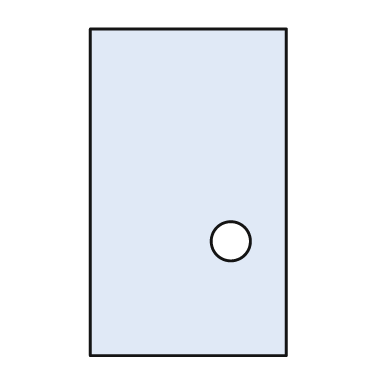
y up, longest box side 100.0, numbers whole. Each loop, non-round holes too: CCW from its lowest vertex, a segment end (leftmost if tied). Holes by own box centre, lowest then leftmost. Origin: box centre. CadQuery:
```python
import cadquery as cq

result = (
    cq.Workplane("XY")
    .moveTo(-30.0, -50.0)
    .lineTo(30.0, -50.0)
    .lineTo(30.0, 50.0)
    .lineTo(-30.0, 50.0)
    .close()
    .moveTo(13.0, -15.0)
    .circle(6.0)
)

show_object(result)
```